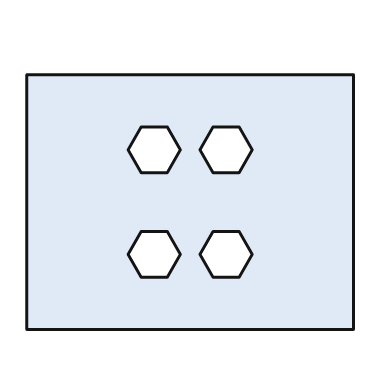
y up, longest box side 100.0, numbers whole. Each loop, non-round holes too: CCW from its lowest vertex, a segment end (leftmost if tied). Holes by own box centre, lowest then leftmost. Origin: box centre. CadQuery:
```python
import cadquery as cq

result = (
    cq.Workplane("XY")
    .moveTo(-50.0, -39.0)
    .lineTo(50.0, -39.0)
    .lineTo(50.0, 39.0)
    .lineTo(-50.0, 39.0)
    .close()
    .moveTo(-15.0, -23.0)
    .lineTo(-7.0, -23.0)
    .lineTo(-3.0, -16.0)
    .lineTo(-7.0, -9.0)
    .lineTo(-15.0, -9.0)
    .lineTo(-19.0, -16.0)
    .close()
    .moveTo(7.0, -23.0)
    .lineTo(15.0, -23.0)
    .lineTo(19.0, -16.0)
    .lineTo(15.0, -9.0)
    .lineTo(7.0, -9.0)
    .lineTo(3.0, -16.0)
    .close()
    .moveTo(-15.0, 9.0)
    .lineTo(-7.0, 9.0)
    .lineTo(-3.0, 16.0)
    .lineTo(-7.0, 23.0)
    .lineTo(-15.0, 23.0)
    .lineTo(-19.0, 16.0)
    .close()
    .moveTo(7.0, 9.0)
    .lineTo(15.0, 9.0)
    .lineTo(19.0, 16.0)
    .lineTo(15.0, 23.0)
    .lineTo(7.0, 23.0)
    .lineTo(3.0, 16.0)
    .close()
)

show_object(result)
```